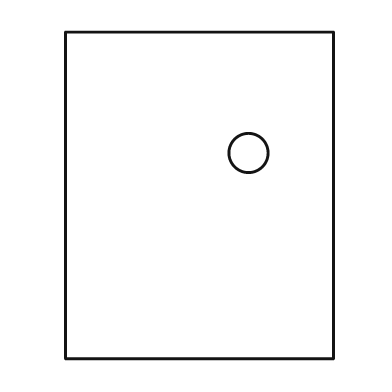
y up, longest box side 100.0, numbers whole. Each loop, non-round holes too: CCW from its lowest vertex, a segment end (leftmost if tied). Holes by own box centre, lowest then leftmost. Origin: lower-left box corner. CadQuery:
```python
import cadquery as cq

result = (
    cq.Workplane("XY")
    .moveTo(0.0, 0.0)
    .lineTo(82.0, 0.0)
    .lineTo(82.0, 100.0)
    .lineTo(0.0, 100.0)
    .close()
    .moveTo(56.0, 63.0)
    .circle(6.0)
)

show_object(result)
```